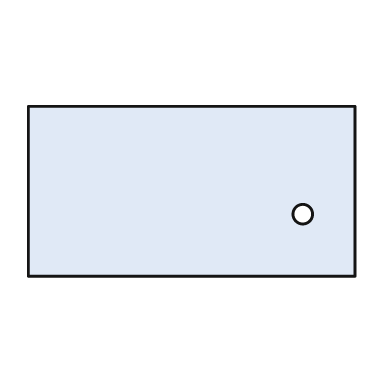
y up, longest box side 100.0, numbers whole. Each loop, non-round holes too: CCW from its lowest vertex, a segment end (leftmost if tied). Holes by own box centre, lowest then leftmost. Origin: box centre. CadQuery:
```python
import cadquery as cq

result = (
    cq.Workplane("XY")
    .moveTo(-50.0, -26.0)
    .lineTo(50.0, -26.0)
    .lineTo(50.0, 26.0)
    .lineTo(-50.0, 26.0)
    .close()
    .moveTo(34.0, -7.0)
    .circle(3.0)
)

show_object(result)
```